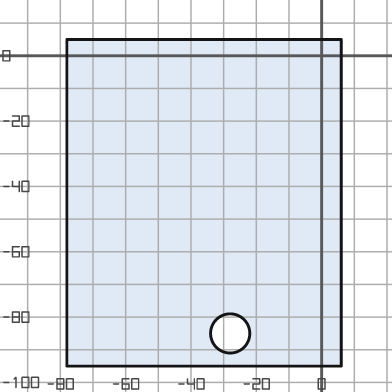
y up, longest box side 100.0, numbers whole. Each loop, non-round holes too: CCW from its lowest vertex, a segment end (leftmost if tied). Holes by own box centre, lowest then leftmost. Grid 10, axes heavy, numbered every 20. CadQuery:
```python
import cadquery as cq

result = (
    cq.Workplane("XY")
    .moveTo(-78.0, -95.0)
    .lineTo(6.0, -95.0)
    .lineTo(6.0, 5.0)
    .lineTo(-78.0, 5.0)
    .close()
    .moveTo(-28.0, -85.0)
    .circle(6.0)
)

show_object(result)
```